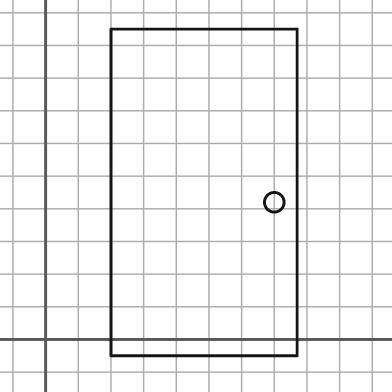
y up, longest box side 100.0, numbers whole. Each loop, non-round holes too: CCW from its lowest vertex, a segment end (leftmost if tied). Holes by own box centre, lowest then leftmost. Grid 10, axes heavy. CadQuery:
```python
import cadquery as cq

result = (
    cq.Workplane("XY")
    .moveTo(20.0, -5.0)
    .lineTo(77.0, -5.0)
    .lineTo(77.0, 95.0)
    .lineTo(20.0, 95.0)
    .close()
    .moveTo(70.0, 42.0)
    .circle(3.0)
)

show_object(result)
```